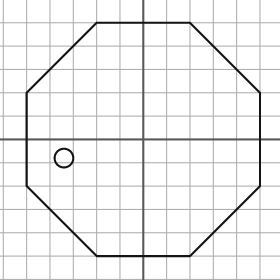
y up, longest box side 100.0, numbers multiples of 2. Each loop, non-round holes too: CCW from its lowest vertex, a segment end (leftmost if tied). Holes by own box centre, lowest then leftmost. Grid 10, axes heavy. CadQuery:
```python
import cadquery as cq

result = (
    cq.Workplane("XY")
    .moveTo(-20.0, -50.0)
    .lineTo(20.0, -50.0)
    .lineTo(50.0, -20.0)
    .lineTo(50.0, 20.0)
    .lineTo(20.0, 50.0)
    .lineTo(-20.0, 50.0)
    .lineTo(-50.0, 20.0)
    .lineTo(-50.0, -20.0)
    .close()
    .moveTo(-34.0, -8.0)
    .circle(4.0)
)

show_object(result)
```